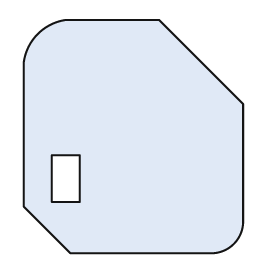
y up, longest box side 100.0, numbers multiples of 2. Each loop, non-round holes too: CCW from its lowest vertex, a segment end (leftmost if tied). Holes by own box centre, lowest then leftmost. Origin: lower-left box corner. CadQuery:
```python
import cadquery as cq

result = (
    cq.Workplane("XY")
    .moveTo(20.0, 0.0)
    .lineTo(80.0, 0.0)
    .threePointArc((90.0, 4.0), (94.0, 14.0))
    .lineTo(94.0, 64.0)
    .lineTo(58.0, 100.0)
    .lineTo(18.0, 100.0)
    .threePointArc((6.0, 94.0), (0.0, 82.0))
    .lineTo(0.0, 20.0)
    .close()
    .moveTo(12.0, 22.0)
    .lineTo(24.0, 22.0)
    .lineTo(24.0, 42.0)
    .lineTo(12.0, 42.0)
    .close()
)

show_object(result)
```